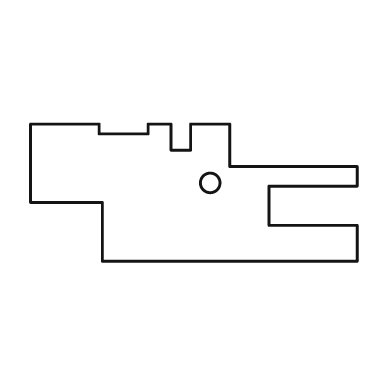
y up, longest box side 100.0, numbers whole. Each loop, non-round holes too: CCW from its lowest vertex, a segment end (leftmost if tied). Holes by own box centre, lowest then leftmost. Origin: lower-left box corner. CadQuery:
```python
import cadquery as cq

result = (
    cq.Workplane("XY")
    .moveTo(22.0, 0.0)
    .lineTo(100.0, 0.0)
    .lineTo(100.0, 11.0)
    .lineTo(73.0, 11.0)
    .lineTo(73.0, 23.0)
    .lineTo(100.0, 23.0)
    .lineTo(100.0, 29.0)
    .lineTo(61.0, 29.0)
    .lineTo(61.0, 42.0)
    .lineTo(49.0, 42.0)
    .lineTo(49.0, 34.0)
    .lineTo(43.0, 34.0)
    .lineTo(43.0, 42.0)
    .lineTo(36.0, 42.0)
    .lineTo(36.0, 39.0)
    .lineTo(21.0, 39.0)
    .lineTo(21.0, 42.0)
    .lineTo(0.0, 42.0)
    .lineTo(0.0, 18.0)
    .lineTo(22.0, 18.0)
    .close()
    .moveTo(55.0, 24.0)
    .circle(3.0)
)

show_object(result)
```